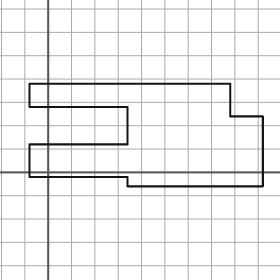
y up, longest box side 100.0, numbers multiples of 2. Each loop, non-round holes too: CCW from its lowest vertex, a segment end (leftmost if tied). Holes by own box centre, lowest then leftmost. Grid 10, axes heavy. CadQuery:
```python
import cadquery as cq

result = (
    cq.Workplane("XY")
    .moveTo(34.0, -6.0)
    .lineTo(92.0, -6.0)
    .lineTo(92.0, 24.0)
    .lineTo(78.0, 24.0)
    .lineTo(78.0, 38.0)
    .lineTo(-8.0, 38.0)
    .lineTo(-8.0, 28.0)
    .lineTo(34.0, 28.0)
    .lineTo(34.0, 12.0)
    .lineTo(-8.0, 12.0)
    .lineTo(-8.0, -2.0)
    .lineTo(34.0, -2.0)
    .close()
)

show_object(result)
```